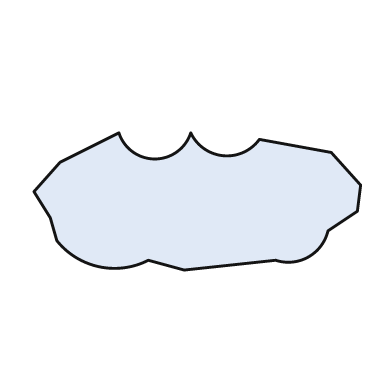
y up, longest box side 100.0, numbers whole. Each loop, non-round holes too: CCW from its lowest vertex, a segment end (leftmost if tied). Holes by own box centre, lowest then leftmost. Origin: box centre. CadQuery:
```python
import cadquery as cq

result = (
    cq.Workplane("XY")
    .moveTo(-4.0, -21.0)
    .lineTo(24.0, -18.0)
    .threePointArc((34.0, -17.0), (40.0, -9.0))
    .lineTo(49.0, -3.0)
    .lineTo(50.0, 5.0)
    .lineTo(41.0, 15.0)
    .lineTo(19.0, 19.0)
    .threePointArc((8.0, 14.0), (-2.0, 21.0))
    .threePointArc((-13.0, 13.0), (-24.0, 21.0))
    .lineTo(-42.0, 12.0)
    .lineTo(-50.0, 3.0)
    .lineTo(-45.0, -5.0)
    .lineTo(-43.0, -12.0)
    .threePointArc((-30.0, -20.0), (-15.0, -18.0))
    .close()
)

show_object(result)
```